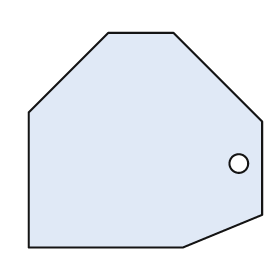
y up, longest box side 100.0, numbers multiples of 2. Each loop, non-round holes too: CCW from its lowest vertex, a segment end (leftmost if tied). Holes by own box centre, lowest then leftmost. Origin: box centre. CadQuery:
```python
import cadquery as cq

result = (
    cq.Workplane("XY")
    .moveTo(-50.0, -46.0)
    .lineTo(16.0, -46.0)
    .lineTo(50.0, -32.0)
    .lineTo(50.0, 8.0)
    .lineTo(12.0, 46.0)
    .lineTo(-16.0, 46.0)
    .lineTo(-50.0, 12.0)
    .close()
    .moveTo(40.0, -10.0)
    .circle(4.0)
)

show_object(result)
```